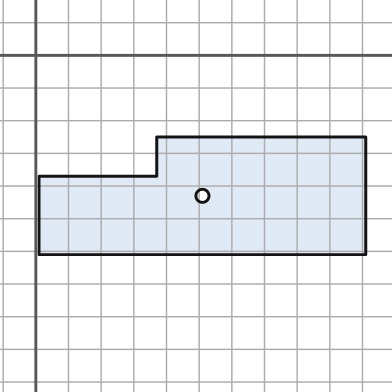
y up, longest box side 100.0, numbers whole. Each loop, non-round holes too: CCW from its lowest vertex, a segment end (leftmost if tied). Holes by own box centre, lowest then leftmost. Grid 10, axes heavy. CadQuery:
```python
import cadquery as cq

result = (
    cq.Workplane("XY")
    .moveTo(1.0, -61.0)
    .lineTo(101.0, -61.0)
    .lineTo(101.0, -25.0)
    .lineTo(37.0, -25.0)
    .lineTo(37.0, -37.0)
    .lineTo(1.0, -37.0)
    .close()
    .moveTo(51.0, -43.0)
    .circle(2.0)
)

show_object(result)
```